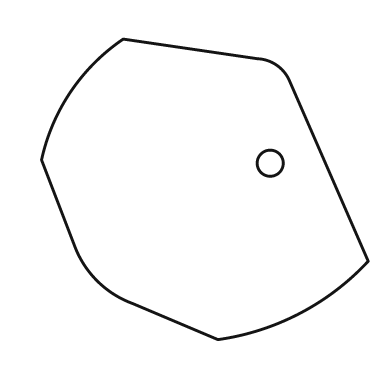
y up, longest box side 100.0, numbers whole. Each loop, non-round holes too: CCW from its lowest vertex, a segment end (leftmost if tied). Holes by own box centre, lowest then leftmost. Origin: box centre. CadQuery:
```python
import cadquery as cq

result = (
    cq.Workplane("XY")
    .moveTo(4.0, -46.0)
    .threePointArc((29.0, -38.0), (50.0, -22.0))
    .lineTo(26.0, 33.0)
    .threePointArc((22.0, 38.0), (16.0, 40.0))
    .lineTo(-25.0, 46.0)
    .threePointArc((-41.0, 30.0), (-50.0, 9.0))
    .lineTo(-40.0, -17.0)
    .threePointArc((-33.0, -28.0), (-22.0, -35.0))
    .close()
    .moveTo(20.0, 8.0)
    .circle(4.0)
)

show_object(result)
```